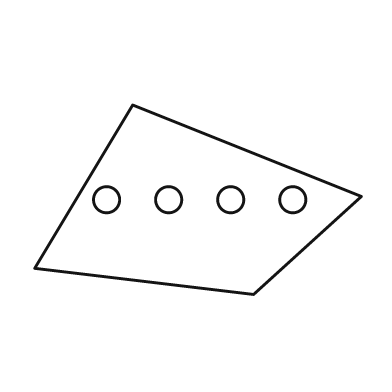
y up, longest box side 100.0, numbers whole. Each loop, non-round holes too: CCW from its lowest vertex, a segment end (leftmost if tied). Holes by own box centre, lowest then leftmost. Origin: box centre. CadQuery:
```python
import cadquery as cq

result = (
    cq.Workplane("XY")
    .moveTo(17.0, -29.0)
    .lineTo(50.0, 1.0)
    .lineTo(-20.0, 29.0)
    .lineTo(-50.0, -21.0)
    .close()
    .moveTo(-28.0, 0.0)
    .circle(4.0)
    .moveTo(-9.0, 0.0)
    .circle(4.0)
    .moveTo(10.0, 0.0)
    .circle(4.0)
    .moveTo(29.0, 0.0)
    .circle(4.0)
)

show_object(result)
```